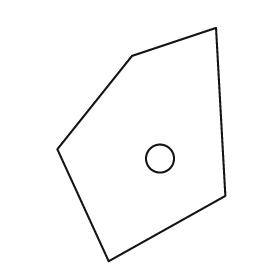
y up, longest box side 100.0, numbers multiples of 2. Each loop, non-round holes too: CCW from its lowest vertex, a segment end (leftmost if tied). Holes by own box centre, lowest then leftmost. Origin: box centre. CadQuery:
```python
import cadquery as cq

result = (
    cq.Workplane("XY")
    .moveTo(-14.0, -50.0)
    .lineTo(36.0, -22.0)
    .lineTo(32.0, 50.0)
    .lineTo(-4.0, 38.0)
    .lineTo(-36.0, -2.0)
    .close()
    .moveTo(8.0, -6.0)
    .circle(6.0)
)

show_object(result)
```